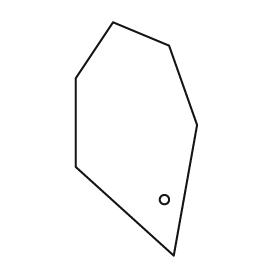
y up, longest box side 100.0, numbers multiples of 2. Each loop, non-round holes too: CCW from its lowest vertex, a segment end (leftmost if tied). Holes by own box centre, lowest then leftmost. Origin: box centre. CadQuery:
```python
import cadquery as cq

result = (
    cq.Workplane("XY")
    .moveTo(16.0, -50.0)
    .lineTo(26.0, 6.0)
    .lineTo(14.0, 40.0)
    .lineTo(-10.0, 50.0)
    .lineTo(-26.0, 26.0)
    .lineTo(-26.0, -12.0)
    .close()
    .moveTo(12.0, -26.0)
    .circle(2.0)
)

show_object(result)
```